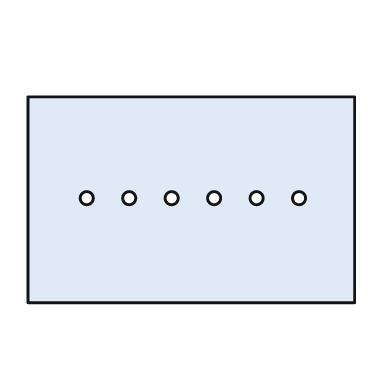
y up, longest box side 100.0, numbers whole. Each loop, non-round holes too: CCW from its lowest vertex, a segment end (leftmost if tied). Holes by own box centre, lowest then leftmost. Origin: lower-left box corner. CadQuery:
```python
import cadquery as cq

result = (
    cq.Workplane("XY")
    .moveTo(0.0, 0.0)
    .lineTo(100.0, 0.0)
    .lineTo(100.0, 63.0)
    .lineTo(0.0, 63.0)
    .close()
    .moveTo(18.0, 32.0)
    .circle(2.0)
    .moveTo(31.0, 32.0)
    .circle(2.0)
    .moveTo(44.0, 32.0)
    .circle(2.0)
    .moveTo(57.0, 32.0)
    .circle(2.0)
    .moveTo(70.0, 32.0)
    .circle(2.0)
    .moveTo(83.0, 32.0)
    .circle(2.0)
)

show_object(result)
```